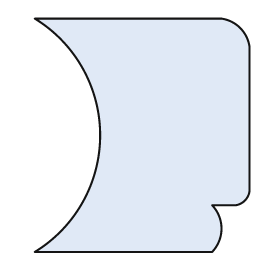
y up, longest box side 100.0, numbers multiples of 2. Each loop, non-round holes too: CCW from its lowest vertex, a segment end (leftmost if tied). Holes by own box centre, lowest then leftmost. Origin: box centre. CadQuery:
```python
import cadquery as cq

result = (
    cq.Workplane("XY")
    .moveTo(-46.0, -50.0)
    .lineTo(30.0, -50.0)
    .threePointArc((34.0, -40.0), (30.0, -30.0))
    .lineTo(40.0, -30.0)
    .threePointArc((44.0, -28.0), (46.0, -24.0))
    .lineTo(46.0, 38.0)
    .threePointArc((42.0, 46.0), (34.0, 50.0))
    .lineTo(-46.0, 50.0)
    .threePointArc((-18.0, 0.0), (-46.0, -50.0))
    .close()
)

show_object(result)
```